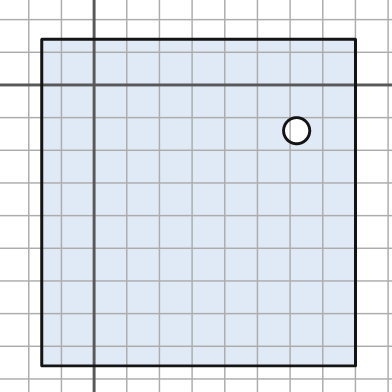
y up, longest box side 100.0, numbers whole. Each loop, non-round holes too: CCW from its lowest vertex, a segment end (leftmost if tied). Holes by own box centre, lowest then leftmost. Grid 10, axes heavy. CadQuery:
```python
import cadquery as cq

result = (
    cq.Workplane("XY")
    .moveTo(-16.0, -86.0)
    .lineTo(80.0, -86.0)
    .lineTo(80.0, 14.0)
    .lineTo(-16.0, 14.0)
    .close()
    .moveTo(62.0, -14.0)
    .circle(4.0)
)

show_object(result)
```